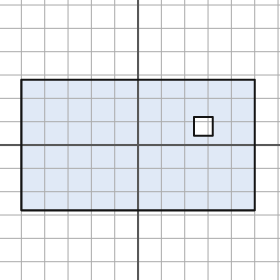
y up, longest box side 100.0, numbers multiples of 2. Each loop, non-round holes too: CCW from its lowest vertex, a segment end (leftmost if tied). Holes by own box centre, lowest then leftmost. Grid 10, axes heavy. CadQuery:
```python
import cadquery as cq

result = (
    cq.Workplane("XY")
    .moveTo(-50.0, -28.0)
    .lineTo(50.0, -28.0)
    .lineTo(50.0, 28.0)
    .lineTo(-50.0, 28.0)
    .close()
    .moveTo(24.0, 4.0)
    .lineTo(32.0, 4.0)
    .lineTo(32.0, 12.0)
    .lineTo(24.0, 12.0)
    .close()
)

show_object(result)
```